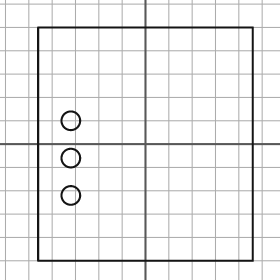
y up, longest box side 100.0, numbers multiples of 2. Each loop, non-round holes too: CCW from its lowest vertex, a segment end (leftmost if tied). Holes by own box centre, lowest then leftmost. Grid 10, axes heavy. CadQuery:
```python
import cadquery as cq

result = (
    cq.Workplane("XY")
    .moveTo(-46.0, -50.0)
    .lineTo(46.0, -50.0)
    .lineTo(46.0, 50.0)
    .lineTo(-46.0, 50.0)
    .close()
    .moveTo(-32.0, -22.0)
    .circle(4.0)
    .moveTo(-32.0, -6.0)
    .circle(4.0)
    .moveTo(-32.0, 10.0)
    .circle(4.0)
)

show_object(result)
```